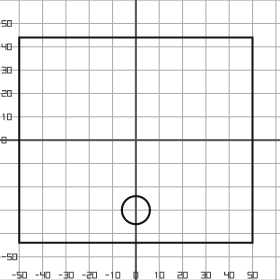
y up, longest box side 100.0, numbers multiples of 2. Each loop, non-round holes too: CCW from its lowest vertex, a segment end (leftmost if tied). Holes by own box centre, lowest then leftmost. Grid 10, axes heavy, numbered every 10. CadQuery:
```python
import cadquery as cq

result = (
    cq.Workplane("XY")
    .moveTo(-50.0, -44.0)
    .lineTo(50.0, -44.0)
    .lineTo(50.0, 44.0)
    .lineTo(-50.0, 44.0)
    .close()
    .moveTo(0.0, -30.0)
    .circle(6.0)
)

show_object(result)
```